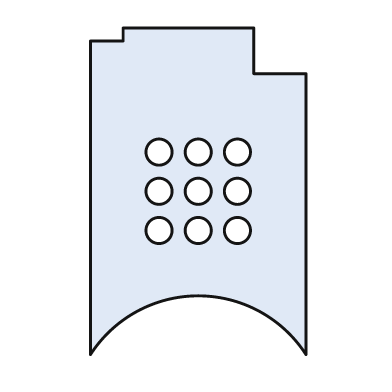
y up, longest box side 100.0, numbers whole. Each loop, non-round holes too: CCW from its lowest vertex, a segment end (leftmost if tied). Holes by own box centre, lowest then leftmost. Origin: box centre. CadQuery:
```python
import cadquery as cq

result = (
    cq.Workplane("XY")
    .moveTo(-33.0, -50.0)
    .threePointArc((0.0, -32.0), (33.0, -50.0))
    .lineTo(33.0, 36.0)
    .lineTo(17.0, 36.0)
    .lineTo(17.0, 50.0)
    .lineTo(-23.0, 50.0)
    .lineTo(-23.0, 46.0)
    .lineTo(-33.0, 46.0)
    .close()
    .moveTo(-12.0, -12.0)
    .circle(4.0)
    .moveTo(0.0, -12.0)
    .circle(4.0)
    .moveTo(12.0, -12.0)
    .circle(4.0)
    .moveTo(-12.0, 0.0)
    .circle(4.0)
    .moveTo(0.0, 0.0)
    .circle(4.0)
    .moveTo(12.0, 0.0)
    .circle(4.0)
    .moveTo(-12.0, 12.0)
    .circle(4.0)
    .moveTo(0.0, 12.0)
    .circle(4.0)
    .moveTo(12.0, 12.0)
    .circle(4.0)
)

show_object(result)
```